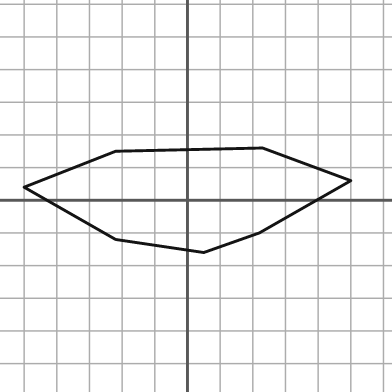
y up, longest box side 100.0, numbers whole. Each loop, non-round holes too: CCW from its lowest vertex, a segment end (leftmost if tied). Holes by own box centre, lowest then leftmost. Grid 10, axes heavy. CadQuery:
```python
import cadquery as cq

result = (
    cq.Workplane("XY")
    .moveTo(5.0, -16.0)
    .lineTo(22.0, -10.0)
    .lineTo(50.0, 6.0)
    .lineTo(23.0, 16.0)
    .lineTo(-22.0, 15.0)
    .lineTo(-50.0, 4.0)
    .lineTo(-22.0, -12.0)
    .close()
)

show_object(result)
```